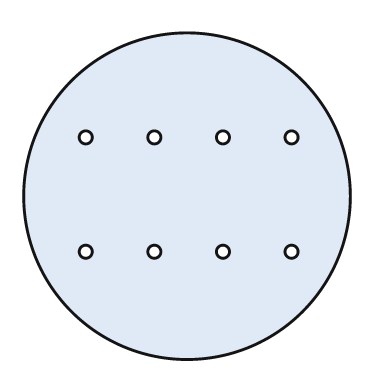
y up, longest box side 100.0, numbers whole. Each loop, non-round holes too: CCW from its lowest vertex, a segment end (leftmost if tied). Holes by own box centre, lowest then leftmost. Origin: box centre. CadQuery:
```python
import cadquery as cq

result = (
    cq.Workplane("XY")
    .moveTo(0.0, 0.0)
    .circle(50.0)
    .moveTo(-31.0, -17.0)
    .circle(2.0)
    .moveTo(-10.0, -17.0)
    .circle(2.0)
    .moveTo(11.0, -17.0)
    .circle(2.0)
    .moveTo(32.0, -17.0)
    .circle(2.0)
    .moveTo(-31.0, 18.0)
    .circle(2.0)
    .moveTo(-10.0, 18.0)
    .circle(2.0)
    .moveTo(11.0, 18.0)
    .circle(2.0)
    .moveTo(32.0, 18.0)
    .circle(2.0)
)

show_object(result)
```